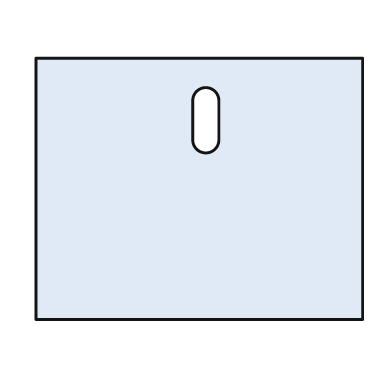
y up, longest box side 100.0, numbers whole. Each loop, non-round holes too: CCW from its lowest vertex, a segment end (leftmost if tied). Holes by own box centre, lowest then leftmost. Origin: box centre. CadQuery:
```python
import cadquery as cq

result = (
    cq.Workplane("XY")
    .moveTo(-50.0, -40.0)
    .lineTo(50.0, -40.0)
    .lineTo(50.0, 40.0)
    .lineTo(-50.0, 40.0)
    .close()
    .moveTo(-2.0, 15.0)
    .threePointArc((2.0, 11.0), (6.0, 15.0))
    .lineTo(6.0, 27.0)
    .threePointArc((2.0, 31.0), (-2.0, 27.0))
    .close()
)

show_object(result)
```